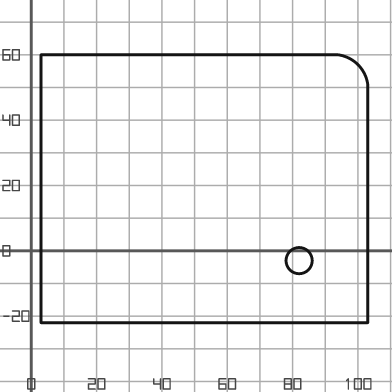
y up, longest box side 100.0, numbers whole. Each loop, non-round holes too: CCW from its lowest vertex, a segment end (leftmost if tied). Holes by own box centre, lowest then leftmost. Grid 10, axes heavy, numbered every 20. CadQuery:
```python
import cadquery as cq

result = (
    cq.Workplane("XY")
    .moveTo(3.0, -22.0)
    .lineTo(103.0, -22.0)
    .lineTo(103.0, 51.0)
    .threePointArc((100.0, 57.0), (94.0, 60.0))
    .lineTo(3.0, 60.0)
    .close()
    .moveTo(82.0, -3.0)
    .circle(4.0)
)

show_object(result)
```